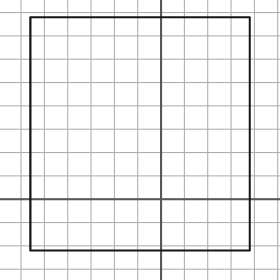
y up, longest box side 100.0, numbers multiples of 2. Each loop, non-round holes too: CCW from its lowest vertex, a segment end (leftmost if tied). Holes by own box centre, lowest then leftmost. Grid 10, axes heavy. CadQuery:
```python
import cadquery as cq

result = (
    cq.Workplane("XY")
    .moveTo(-56.0, -22.0)
    .lineTo(38.0, -22.0)
    .lineTo(38.0, 78.0)
    .lineTo(-56.0, 78.0)
    .close()
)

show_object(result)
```